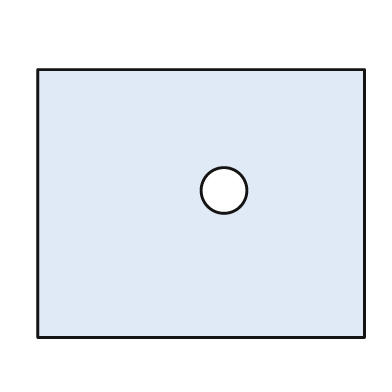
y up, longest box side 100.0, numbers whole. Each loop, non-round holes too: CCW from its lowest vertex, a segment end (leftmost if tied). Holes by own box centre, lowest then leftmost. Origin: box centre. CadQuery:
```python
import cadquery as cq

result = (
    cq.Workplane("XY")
    .moveTo(-50.0, -41.0)
    .lineTo(50.0, -41.0)
    .lineTo(50.0, 41.0)
    .lineTo(-50.0, 41.0)
    .close()
    .moveTo(7.0, 4.0)
    .circle(7.0)
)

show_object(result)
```